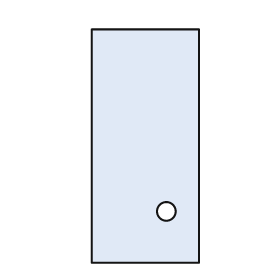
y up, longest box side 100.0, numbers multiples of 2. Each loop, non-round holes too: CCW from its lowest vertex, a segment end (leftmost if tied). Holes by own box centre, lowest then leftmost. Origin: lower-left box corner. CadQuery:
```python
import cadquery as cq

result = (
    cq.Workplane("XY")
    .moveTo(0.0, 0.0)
    .lineTo(46.0, 0.0)
    .lineTo(46.0, 100.0)
    .lineTo(0.0, 100.0)
    .close()
    .moveTo(32.0, 22.0)
    .circle(4.0)
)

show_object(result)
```